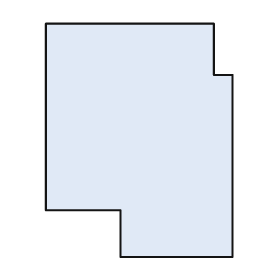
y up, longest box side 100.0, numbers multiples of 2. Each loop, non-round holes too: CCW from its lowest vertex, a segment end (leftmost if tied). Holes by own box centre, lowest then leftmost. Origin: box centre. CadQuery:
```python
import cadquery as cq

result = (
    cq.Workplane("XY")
    .moveTo(-8.0, -50.0)
    .lineTo(40.0, -50.0)
    .lineTo(40.0, 28.0)
    .lineTo(32.0, 28.0)
    .lineTo(32.0, 50.0)
    .lineTo(-40.0, 50.0)
    .lineTo(-40.0, -30.0)
    .lineTo(-8.0, -30.0)
    .close()
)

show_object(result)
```